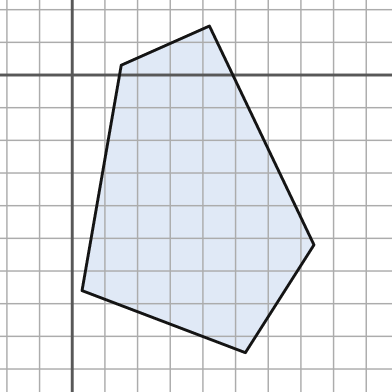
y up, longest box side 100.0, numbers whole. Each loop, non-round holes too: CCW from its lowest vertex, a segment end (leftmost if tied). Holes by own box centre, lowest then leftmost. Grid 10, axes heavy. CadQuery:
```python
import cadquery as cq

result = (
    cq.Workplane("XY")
    .moveTo(53.0, -85.0)
    .lineTo(74.0, -52.0)
    .lineTo(42.0, 15.0)
    .lineTo(15.0, 3.0)
    .lineTo(3.0, -66.0)
    .close()
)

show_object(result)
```